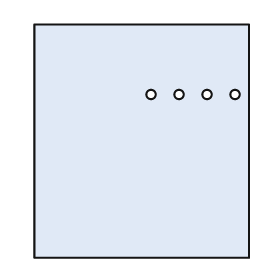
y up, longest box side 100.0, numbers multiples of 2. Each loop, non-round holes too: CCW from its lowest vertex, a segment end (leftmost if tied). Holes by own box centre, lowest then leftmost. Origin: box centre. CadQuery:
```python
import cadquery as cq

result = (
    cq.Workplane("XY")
    .moveTo(-46.0, -50.0)
    .lineTo(46.0, -50.0)
    .lineTo(46.0, 50.0)
    .lineTo(-46.0, 50.0)
    .close()
    .moveTo(4.0, 20.0)
    .circle(2.0)
    .moveTo(16.0, 20.0)
    .circle(2.0)
    .moveTo(28.0, 20.0)
    .circle(2.0)
    .moveTo(40.0, 20.0)
    .circle(2.0)
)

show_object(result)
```